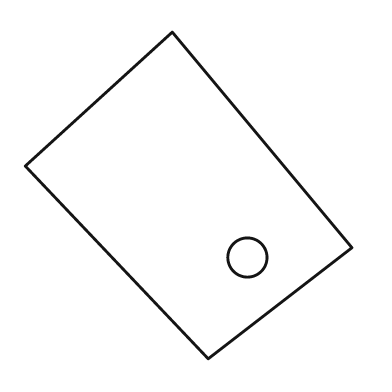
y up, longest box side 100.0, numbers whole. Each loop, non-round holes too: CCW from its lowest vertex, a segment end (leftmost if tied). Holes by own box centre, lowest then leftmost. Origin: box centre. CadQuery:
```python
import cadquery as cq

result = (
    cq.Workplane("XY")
    .moveTo(6.0, -50.0)
    .lineTo(50.0, -16.0)
    .lineTo(-5.0, 50.0)
    .lineTo(-50.0, 9.0)
    .close()
    .moveTo(18.0, -19.0)
    .circle(6.0)
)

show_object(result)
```